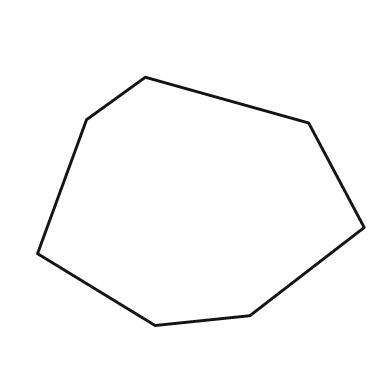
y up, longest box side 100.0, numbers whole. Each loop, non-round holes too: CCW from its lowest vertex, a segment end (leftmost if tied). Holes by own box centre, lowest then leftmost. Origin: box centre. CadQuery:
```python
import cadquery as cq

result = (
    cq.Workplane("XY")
    .moveTo(-14.0, -38.0)
    .lineTo(15.0, -35.0)
    .lineTo(50.0, -8.0)
    .lineTo(33.0, 24.0)
    .lineTo(-17.0, 38.0)
    .lineTo(-35.0, 25.0)
    .lineTo(-50.0, -16.0)
    .close()
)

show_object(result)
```